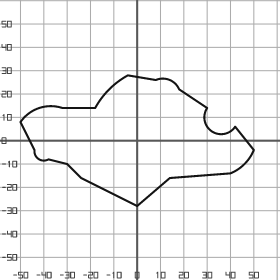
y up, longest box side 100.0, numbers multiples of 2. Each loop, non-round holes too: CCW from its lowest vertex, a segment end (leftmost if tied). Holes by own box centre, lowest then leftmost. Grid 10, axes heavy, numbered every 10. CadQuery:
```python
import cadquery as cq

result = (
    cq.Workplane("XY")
    .moveTo(0.0, -28.0)
    .lineTo(14.0, -16.0)
    .lineTo(40.0, -14.0)
    .threePointArc((46.0, -10.0), (50.0, -4.0))
    .lineTo(42.0, 6.0)
    .threePointArc((32.0, 4.0), (30.0, 14.0))
    .lineTo(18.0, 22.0)
    .threePointArc((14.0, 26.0), (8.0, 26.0))
    .lineTo(-4.0, 28.0)
    .threePointArc((-12.0, 22.0), (-18.0, 14.0))
    .lineTo(-32.0, 14.0)
    .threePointArc((-42.0, 14.0), (-50.0, 8.0))
    .lineTo(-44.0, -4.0)
    .threePointArc((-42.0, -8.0), (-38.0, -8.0))
    .lineTo(-30.0, -10.0)
    .lineTo(-24.0, -16.0)
    .close()
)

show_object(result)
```